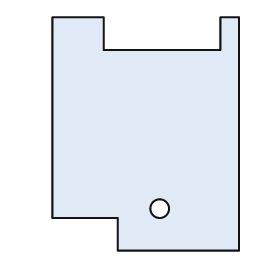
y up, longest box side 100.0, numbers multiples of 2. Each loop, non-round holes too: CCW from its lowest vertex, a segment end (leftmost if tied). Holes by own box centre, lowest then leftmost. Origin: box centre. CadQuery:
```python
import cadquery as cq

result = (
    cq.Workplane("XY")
    .moveTo(-12.0, -50.0)
    .lineTo(40.0, -50.0)
    .lineTo(40.0, 50.0)
    .lineTo(32.0, 50.0)
    .lineTo(32.0, 36.0)
    .lineTo(-18.0, 36.0)
    .lineTo(-18.0, 50.0)
    .lineTo(-40.0, 50.0)
    .lineTo(-40.0, -36.0)
    .lineTo(-12.0, -36.0)
    .close()
    .moveTo(6.0, -32.0)
    .circle(4.0)
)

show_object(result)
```